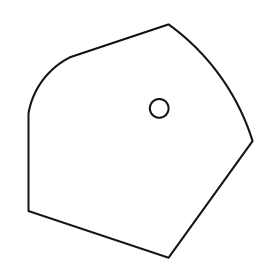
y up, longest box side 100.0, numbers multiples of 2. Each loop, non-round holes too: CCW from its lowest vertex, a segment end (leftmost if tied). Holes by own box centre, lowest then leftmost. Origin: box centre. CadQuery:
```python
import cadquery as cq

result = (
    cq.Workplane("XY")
    .moveTo(12.0, -50.0)
    .lineTo(48.0, 0.0)
    .threePointArc((34.0, 28.0), (12.0, 50.0))
    .lineTo(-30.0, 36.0)
    .threePointArc((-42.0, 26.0), (-48.0, 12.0))
    .lineTo(-48.0, -30.0)
    .close()
    .moveTo(8.0, 14.0)
    .circle(4.0)
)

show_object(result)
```